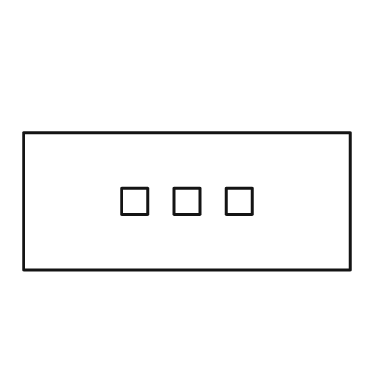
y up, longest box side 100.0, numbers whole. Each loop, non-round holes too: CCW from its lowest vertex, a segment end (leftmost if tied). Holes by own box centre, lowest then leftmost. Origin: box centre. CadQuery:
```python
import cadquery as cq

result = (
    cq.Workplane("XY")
    .moveTo(-50.0, -21.0)
    .lineTo(50.0, -21.0)
    .lineTo(50.0, 21.0)
    .lineTo(-50.0, 21.0)
    .close()
    .moveTo(-20.0, -4.0)
    .lineTo(-12.0, -4.0)
    .lineTo(-12.0, 4.0)
    .lineTo(-20.0, 4.0)
    .close()
    .moveTo(-4.0, -4.0)
    .lineTo(4.0, -4.0)
    .lineTo(4.0, 4.0)
    .lineTo(-4.0, 4.0)
    .close()
    .moveTo(12.0, -4.0)
    .lineTo(20.0, -4.0)
    .lineTo(20.0, 4.0)
    .lineTo(12.0, 4.0)
    .close()
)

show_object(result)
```